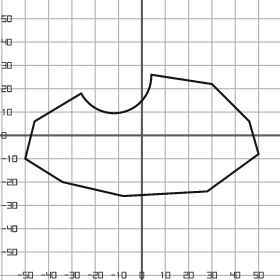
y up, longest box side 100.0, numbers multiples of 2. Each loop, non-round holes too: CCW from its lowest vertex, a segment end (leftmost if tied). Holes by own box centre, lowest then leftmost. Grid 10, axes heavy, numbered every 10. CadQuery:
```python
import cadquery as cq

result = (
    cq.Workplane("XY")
    .moveTo(-8.0, -26.0)
    .lineTo(28.0, -24.0)
    .lineTo(50.0, -8.0)
    .lineTo(46.0, 6.0)
    .lineTo(30.0, 22.0)
    .lineTo(4.0, 26.0)
    .threePointArc((-8.0, 10.0), (-26.0, 18.0))
    .lineTo(-46.0, 6.0)
    .lineTo(-50.0, -10.0)
    .lineTo(-34.0, -20.0)
    .close()
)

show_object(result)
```